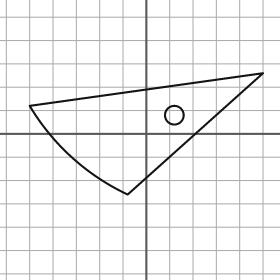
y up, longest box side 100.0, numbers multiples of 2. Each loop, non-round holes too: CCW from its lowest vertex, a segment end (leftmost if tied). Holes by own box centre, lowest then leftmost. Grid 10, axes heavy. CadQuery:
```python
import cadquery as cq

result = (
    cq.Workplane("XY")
    .moveTo(-8.0, -26.0)
    .lineTo(50.0, 26.0)
    .lineTo(-50.0, 12.0)
    .threePointArc((-32.0, -10.0), (-8.0, -26.0))
    .close()
    .moveTo(12.0, 8.0)
    .circle(4.0)
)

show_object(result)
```